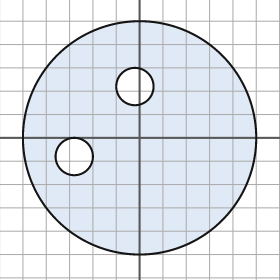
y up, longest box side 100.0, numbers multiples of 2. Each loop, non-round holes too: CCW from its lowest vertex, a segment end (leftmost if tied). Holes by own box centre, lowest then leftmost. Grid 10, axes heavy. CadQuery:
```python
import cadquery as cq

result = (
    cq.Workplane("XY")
    .moveTo(0.0, 0.0)
    .circle(50.0)
    .moveTo(-28.0, -8.0)
    .circle(8.0)
    .moveTo(-2.0, 22.0)
    .circle(8.0)
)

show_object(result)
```